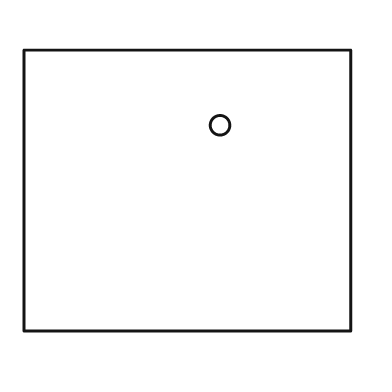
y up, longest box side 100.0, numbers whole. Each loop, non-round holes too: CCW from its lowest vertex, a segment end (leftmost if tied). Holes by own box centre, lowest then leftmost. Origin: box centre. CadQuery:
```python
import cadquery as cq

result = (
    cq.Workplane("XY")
    .moveTo(-50.0, -43.0)
    .lineTo(50.0, -43.0)
    .lineTo(50.0, 43.0)
    .lineTo(-50.0, 43.0)
    .close()
    .moveTo(10.0, 20.0)
    .circle(3.0)
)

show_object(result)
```